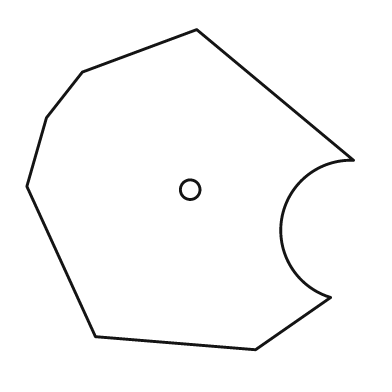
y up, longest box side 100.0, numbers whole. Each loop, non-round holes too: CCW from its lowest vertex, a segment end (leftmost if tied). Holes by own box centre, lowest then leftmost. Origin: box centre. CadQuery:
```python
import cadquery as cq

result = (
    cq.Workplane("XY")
    .moveTo(20.0, -49.0)
    .lineTo(43.0, -33.0)
    .threePointArc((28.0, -9.0), (50.0, 9.0))
    .lineTo(2.0, 49.0)
    .lineTo(-33.0, 36.0)
    .lineTo(-44.0, 22.0)
    .lineTo(-50.0, 1.0)
    .lineTo(-29.0, -45.0)
    .close()
    .moveTo(0.0, 0.0)
    .circle(3.0)
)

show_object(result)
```